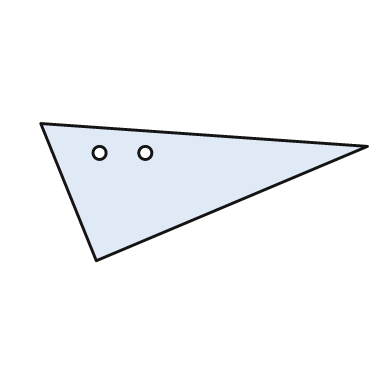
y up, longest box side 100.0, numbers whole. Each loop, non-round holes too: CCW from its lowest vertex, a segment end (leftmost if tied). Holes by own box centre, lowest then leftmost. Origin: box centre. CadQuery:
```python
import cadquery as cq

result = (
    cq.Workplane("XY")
    .moveTo(-33.0, -21.0)
    .lineTo(50.0, 14.0)
    .lineTo(-50.0, 21.0)
    .close()
    .moveTo(-32.0, 12.0)
    .circle(2.0)
    .moveTo(-18.0, 12.0)
    .circle(2.0)
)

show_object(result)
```